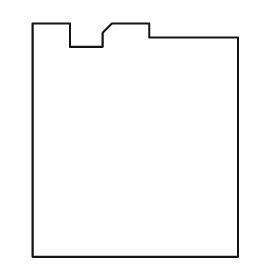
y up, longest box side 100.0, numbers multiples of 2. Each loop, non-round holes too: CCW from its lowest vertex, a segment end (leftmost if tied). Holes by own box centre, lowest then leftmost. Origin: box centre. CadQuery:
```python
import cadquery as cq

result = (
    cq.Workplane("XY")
    .moveTo(-44.0, -50.0)
    .lineTo(44.0, -50.0)
    .lineTo(44.0, 44.0)
    .lineTo(6.0, 44.0)
    .lineTo(6.0, 50.0)
    .lineTo(-10.0, 50.0)
    .lineTo(-14.0, 46.0)
    .lineTo(-14.0, 40.0)
    .lineTo(-28.0, 40.0)
    .lineTo(-28.0, 50.0)
    .lineTo(-44.0, 50.0)
    .close()
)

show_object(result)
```